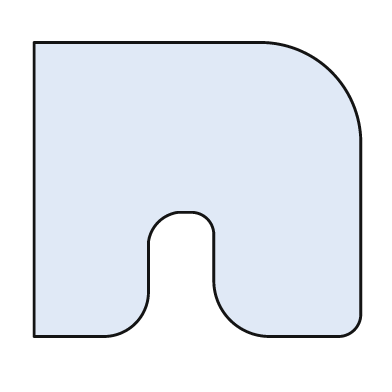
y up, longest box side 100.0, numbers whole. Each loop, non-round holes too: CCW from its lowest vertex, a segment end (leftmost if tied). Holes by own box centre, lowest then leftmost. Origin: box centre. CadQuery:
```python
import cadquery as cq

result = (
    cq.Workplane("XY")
    .moveTo(-50.0, -45.0)
    .lineTo(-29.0, -45.0)
    .threePointArc((-19.0, -41.0), (-15.0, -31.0))
    .lineTo(-15.0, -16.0)
    .threePointArc((-12.0, -10.0), (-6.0, -7.0))
    .lineTo(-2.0, -7.0)
    .threePointArc((3.0, -9.0), (5.0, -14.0))
    .lineTo(5.0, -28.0)
    .threePointArc((10.0, -40.0), (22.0, -45.0))
    .lineTo(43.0, -45.0)
    .threePointArc((48.0, -43.0), (50.0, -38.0))
    .lineTo(50.0, 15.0)
    .threePointArc((41.0, 36.0), (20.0, 45.0))
    .lineTo(-50.0, 45.0)
    .close()
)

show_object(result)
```